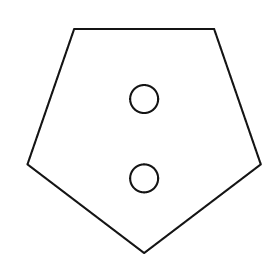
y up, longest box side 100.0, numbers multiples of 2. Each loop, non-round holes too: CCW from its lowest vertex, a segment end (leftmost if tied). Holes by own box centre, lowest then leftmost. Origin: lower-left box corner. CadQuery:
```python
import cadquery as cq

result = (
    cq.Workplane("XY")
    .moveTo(50.0, 0.0)
    .lineTo(100.0, 38.0)
    .lineTo(80.0, 96.0)
    .lineTo(20.0, 96.0)
    .lineTo(0.0, 38.0)
    .close()
    .moveTo(50.0, 32.0)
    .circle(6.0)
    .moveTo(50.0, 66.0)
    .circle(6.0)
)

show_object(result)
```